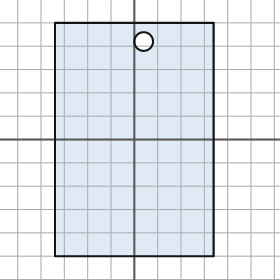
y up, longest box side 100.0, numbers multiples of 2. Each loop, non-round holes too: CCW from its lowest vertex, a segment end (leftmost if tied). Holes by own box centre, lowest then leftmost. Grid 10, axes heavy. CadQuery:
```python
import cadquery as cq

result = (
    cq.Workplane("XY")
    .moveTo(-34.0, -50.0)
    .lineTo(34.0, -50.0)
    .lineTo(34.0, 50.0)
    .lineTo(-34.0, 50.0)
    .close()
    .moveTo(4.0, 42.0)
    .circle(4.0)
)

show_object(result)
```